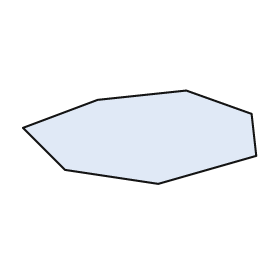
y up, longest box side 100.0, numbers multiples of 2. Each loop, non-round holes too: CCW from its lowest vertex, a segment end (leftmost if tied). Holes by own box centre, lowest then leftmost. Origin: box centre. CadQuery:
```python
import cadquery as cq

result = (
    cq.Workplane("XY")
    .moveTo(8.0, -20.0)
    .lineTo(50.0, -8.0)
    .lineTo(48.0, 10.0)
    .lineTo(20.0, 20.0)
    .lineTo(-18.0, 16.0)
    .lineTo(-50.0, 4.0)
    .lineTo(-32.0, -14.0)
    .close()
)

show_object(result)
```